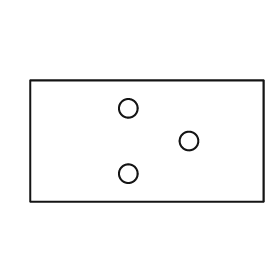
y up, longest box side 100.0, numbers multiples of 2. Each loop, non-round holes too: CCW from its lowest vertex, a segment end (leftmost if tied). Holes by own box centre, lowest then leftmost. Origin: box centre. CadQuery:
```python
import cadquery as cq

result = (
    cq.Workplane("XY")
    .moveTo(-50.0, -26.0)
    .lineTo(50.0, -26.0)
    .lineTo(50.0, 26.0)
    .lineTo(-50.0, 26.0)
    .close()
    .moveTo(-8.0, -14.0)
    .circle(4.0)
    .moveTo(18.0, 0.0)
    .circle(4.0)
    .moveTo(-8.0, 14.0)
    .circle(4.0)
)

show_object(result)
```